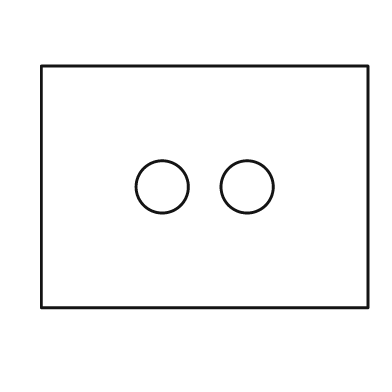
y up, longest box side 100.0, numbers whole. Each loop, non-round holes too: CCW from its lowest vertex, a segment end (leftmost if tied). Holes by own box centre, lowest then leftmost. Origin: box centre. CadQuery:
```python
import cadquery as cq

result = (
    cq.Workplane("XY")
    .moveTo(-50.0, -37.0)
    .lineTo(50.0, -37.0)
    .lineTo(50.0, 37.0)
    .lineTo(-50.0, 37.0)
    .close()
    .moveTo(-13.0, 0.0)
    .circle(8.0)
    .moveTo(13.0, 0.0)
    .circle(8.0)
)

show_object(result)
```